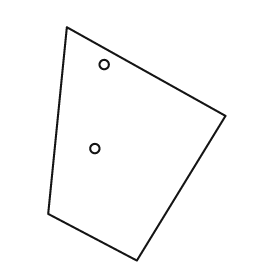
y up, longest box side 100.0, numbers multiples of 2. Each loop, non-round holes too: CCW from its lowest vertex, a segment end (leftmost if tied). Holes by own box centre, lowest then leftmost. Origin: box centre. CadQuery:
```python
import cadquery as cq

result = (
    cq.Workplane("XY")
    .moveTo(0.0, -50.0)
    .lineTo(38.0, 12.0)
    .lineTo(-30.0, 50.0)
    .lineTo(-38.0, -30.0)
    .close()
    .moveTo(-18.0, -2.0)
    .circle(2.0)
    .moveTo(-14.0, 34.0)
    .circle(2.0)
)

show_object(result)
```